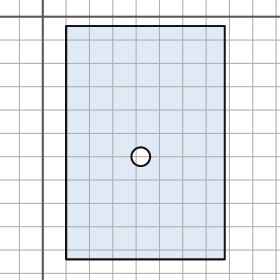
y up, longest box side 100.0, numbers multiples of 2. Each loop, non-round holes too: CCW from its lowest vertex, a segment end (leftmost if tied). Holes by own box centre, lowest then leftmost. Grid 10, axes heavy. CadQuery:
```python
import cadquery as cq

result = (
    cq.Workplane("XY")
    .moveTo(10.0, -104.0)
    .lineTo(78.0, -104.0)
    .lineTo(78.0, -4.0)
    .lineTo(10.0, -4.0)
    .close()
    .moveTo(42.0, -60.0)
    .circle(4.0)
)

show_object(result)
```